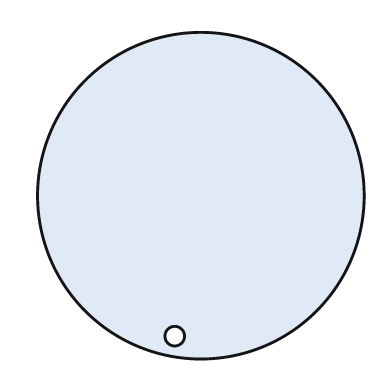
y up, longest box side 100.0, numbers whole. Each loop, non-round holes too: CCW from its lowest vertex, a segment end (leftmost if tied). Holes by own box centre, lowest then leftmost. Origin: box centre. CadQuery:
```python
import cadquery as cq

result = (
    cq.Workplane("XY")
    .moveTo(0.0, 0.0)
    .circle(50.0)
    .moveTo(-8.0, -43.0)
    .circle(3.0)
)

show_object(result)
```